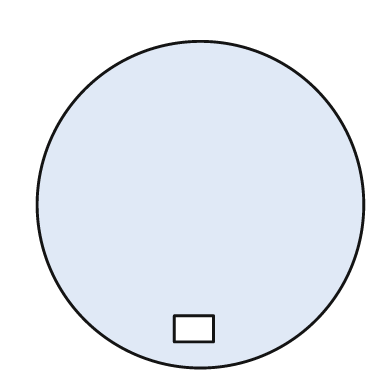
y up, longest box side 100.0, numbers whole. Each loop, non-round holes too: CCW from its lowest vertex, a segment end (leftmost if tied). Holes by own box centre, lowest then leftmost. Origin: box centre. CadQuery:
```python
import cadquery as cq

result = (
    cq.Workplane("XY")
    .moveTo(0.0, 0.0)
    .circle(50.0)
    .moveTo(-8.0, -42.0)
    .lineTo(4.0, -42.0)
    .lineTo(4.0, -34.0)
    .lineTo(-8.0, -34.0)
    .close()
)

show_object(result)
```